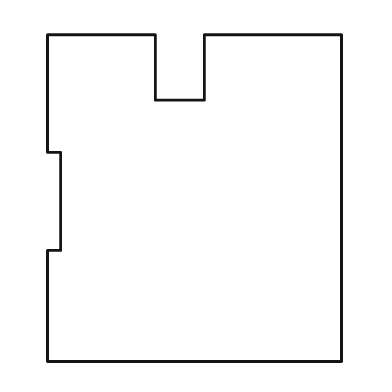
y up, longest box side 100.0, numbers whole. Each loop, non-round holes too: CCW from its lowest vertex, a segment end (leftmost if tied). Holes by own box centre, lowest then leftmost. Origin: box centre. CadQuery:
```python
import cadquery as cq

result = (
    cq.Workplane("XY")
    .moveTo(-45.0, -50.0)
    .lineTo(45.0, -50.0)
    .lineTo(45.0, 50.0)
    .lineTo(3.0, 50.0)
    .lineTo(3.0, 30.0)
    .lineTo(-12.0, 30.0)
    .lineTo(-12.0, 50.0)
    .lineTo(-45.0, 50.0)
    .lineTo(-45.0, 14.0)
    .lineTo(-41.0, 14.0)
    .lineTo(-41.0, -16.0)
    .lineTo(-45.0, -16.0)
    .close()
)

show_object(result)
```